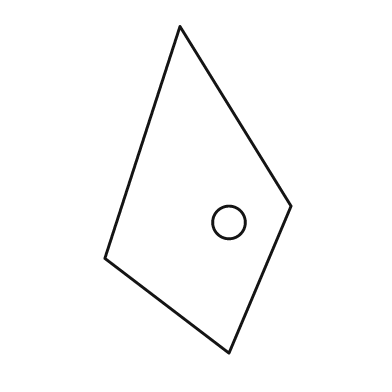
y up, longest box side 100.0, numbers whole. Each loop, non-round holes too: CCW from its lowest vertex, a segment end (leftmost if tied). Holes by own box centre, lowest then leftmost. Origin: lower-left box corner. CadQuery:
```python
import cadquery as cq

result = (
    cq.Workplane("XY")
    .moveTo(38.0, 0.0)
    .lineTo(57.0, 45.0)
    .lineTo(23.0, 100.0)
    .lineTo(0.0, 29.0)
    .close()
    .moveTo(38.0, 40.0)
    .circle(5.0)
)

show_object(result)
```